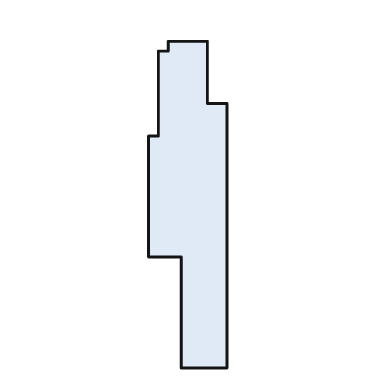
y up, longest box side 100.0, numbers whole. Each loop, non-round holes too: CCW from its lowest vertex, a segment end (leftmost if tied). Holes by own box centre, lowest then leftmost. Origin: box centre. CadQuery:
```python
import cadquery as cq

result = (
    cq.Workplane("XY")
    .moveTo(-2.0, -50.0)
    .lineTo(12.0, -50.0)
    .lineTo(12.0, 31.0)
    .lineTo(6.0, 31.0)
    .lineTo(6.0, 50.0)
    .lineTo(-6.0, 50.0)
    .lineTo(-6.0, 47.0)
    .lineTo(-9.0, 47.0)
    .lineTo(-9.0, 21.0)
    .lineTo(-12.0, 21.0)
    .lineTo(-12.0, -16.0)
    .lineTo(-2.0, -16.0)
    .close()
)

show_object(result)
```